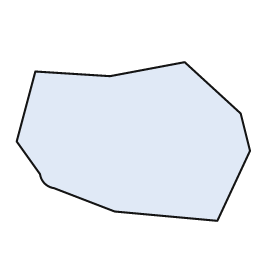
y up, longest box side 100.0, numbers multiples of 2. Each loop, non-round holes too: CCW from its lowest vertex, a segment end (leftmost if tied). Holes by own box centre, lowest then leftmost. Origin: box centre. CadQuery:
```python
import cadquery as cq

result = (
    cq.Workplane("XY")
    .moveTo(36.0, -34.0)
    .lineTo(50.0, -4.0)
    .lineTo(46.0, 12.0)
    .lineTo(22.0, 34.0)
    .lineTo(-10.0, 28.0)
    .lineTo(-42.0, 30.0)
    .lineTo(-50.0, 0.0)
    .lineTo(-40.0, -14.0)
    .threePointArc((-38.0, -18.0), (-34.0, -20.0))
    .lineTo(-8.0, -30.0)
    .close()
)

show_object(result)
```